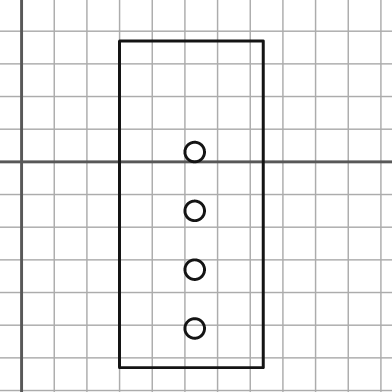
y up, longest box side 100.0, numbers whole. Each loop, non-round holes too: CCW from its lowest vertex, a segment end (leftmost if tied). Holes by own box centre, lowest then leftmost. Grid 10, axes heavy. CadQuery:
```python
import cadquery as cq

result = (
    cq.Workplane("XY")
    .moveTo(30.0, -63.0)
    .lineTo(74.0, -63.0)
    .lineTo(74.0, 37.0)
    .lineTo(30.0, 37.0)
    .close()
    .moveTo(53.0, -51.0)
    .circle(3.0)
    .moveTo(53.0, -33.0)
    .circle(3.0)
    .moveTo(53.0, -15.0)
    .circle(3.0)
    .moveTo(53.0, 3.0)
    .circle(3.0)
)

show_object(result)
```